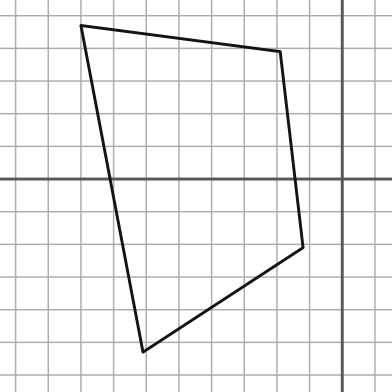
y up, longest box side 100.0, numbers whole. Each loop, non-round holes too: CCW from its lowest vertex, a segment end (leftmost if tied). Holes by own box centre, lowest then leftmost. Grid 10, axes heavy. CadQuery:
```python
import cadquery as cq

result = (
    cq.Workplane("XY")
    .moveTo(-61.0, -53.0)
    .lineTo(-12.0, -21.0)
    .lineTo(-19.0, 39.0)
    .lineTo(-80.0, 47.0)
    .close()
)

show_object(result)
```